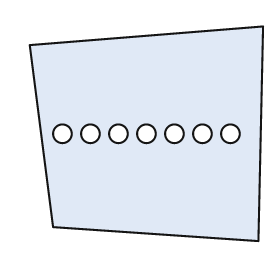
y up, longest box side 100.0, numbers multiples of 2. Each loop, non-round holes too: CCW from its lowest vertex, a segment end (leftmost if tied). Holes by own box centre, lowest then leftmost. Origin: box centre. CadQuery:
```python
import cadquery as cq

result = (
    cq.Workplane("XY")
    .moveTo(48.0, -46.0)
    .lineTo(50.0, 46.0)
    .lineTo(-50.0, 38.0)
    .lineTo(-40.0, -40.0)
    .close()
    .moveTo(-36.0, 0.0)
    .circle(4.0)
    .moveTo(-24.0, 0.0)
    .circle(4.0)
    .moveTo(-12.0, 0.0)
    .circle(4.0)
    .moveTo(0.0, 0.0)
    .circle(4.0)
    .moveTo(12.0, 0.0)
    .circle(4.0)
    .moveTo(24.0, 0.0)
    .circle(4.0)
    .moveTo(36.0, 0.0)
    .circle(4.0)
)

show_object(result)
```